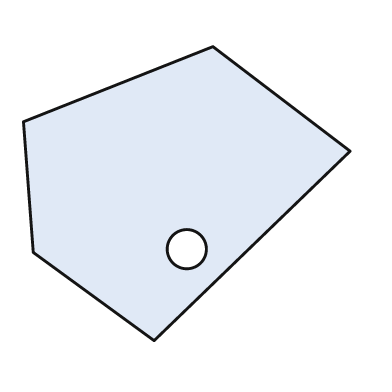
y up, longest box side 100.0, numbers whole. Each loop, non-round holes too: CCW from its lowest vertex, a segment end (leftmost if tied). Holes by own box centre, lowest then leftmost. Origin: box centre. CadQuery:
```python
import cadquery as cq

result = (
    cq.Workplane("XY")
    .moveTo(-10.0, -45.0)
    .lineTo(50.0, 13.0)
    .lineTo(8.0, 45.0)
    .lineTo(-50.0, 22.0)
    .lineTo(-47.0, -18.0)
    .close()
    .moveTo(0.0, -17.0)
    .circle(6.0)
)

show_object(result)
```